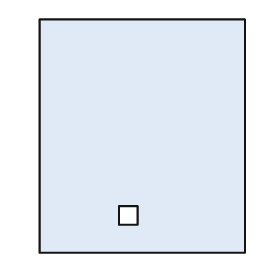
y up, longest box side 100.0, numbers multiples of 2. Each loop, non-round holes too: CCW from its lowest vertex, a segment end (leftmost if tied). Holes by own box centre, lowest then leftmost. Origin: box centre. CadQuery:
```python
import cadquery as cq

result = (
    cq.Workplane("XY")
    .moveTo(-44.0, -50.0)
    .lineTo(44.0, -50.0)
    .lineTo(44.0, 50.0)
    .lineTo(-44.0, 50.0)
    .close()
    .moveTo(-10.0, -38.0)
    .lineTo(-2.0, -38.0)
    .lineTo(-2.0, -30.0)
    .lineTo(-10.0, -30.0)
    .close()
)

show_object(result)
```